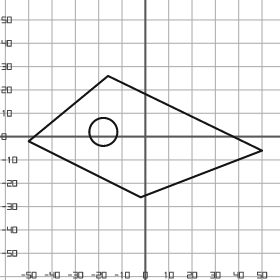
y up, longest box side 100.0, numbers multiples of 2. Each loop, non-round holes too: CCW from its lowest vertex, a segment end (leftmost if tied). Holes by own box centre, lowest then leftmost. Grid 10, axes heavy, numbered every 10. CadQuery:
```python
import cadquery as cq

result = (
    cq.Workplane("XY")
    .moveTo(-2.0, -26.0)
    .lineTo(50.0, -6.0)
    .lineTo(-16.0, 26.0)
    .lineTo(-50.0, -2.0)
    .close()
    .moveTo(-18.0, 2.0)
    .circle(6.0)
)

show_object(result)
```